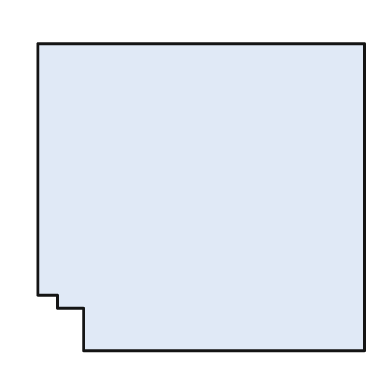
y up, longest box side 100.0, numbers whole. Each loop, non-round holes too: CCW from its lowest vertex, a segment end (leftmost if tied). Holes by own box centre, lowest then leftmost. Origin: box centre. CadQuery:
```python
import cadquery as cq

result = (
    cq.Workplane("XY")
    .moveTo(-36.0, -47.0)
    .lineTo(50.0, -47.0)
    .lineTo(50.0, 47.0)
    .lineTo(-50.0, 47.0)
    .lineTo(-50.0, -30.0)
    .lineTo(-44.0, -30.0)
    .lineTo(-44.0, -34.0)
    .lineTo(-36.0, -34.0)
    .close()
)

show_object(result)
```